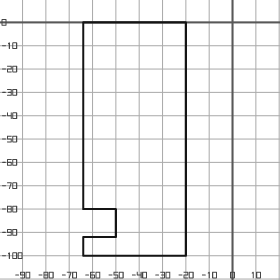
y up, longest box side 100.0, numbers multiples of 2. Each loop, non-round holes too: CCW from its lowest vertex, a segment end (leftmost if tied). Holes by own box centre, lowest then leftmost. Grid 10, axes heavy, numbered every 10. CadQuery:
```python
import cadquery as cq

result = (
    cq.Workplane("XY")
    .moveTo(-64.0, -100.0)
    .lineTo(-20.0, -100.0)
    .lineTo(-20.0, 0.0)
    .lineTo(-64.0, 0.0)
    .lineTo(-64.0, -80.0)
    .lineTo(-50.0, -80.0)
    .lineTo(-50.0, -92.0)
    .lineTo(-64.0, -92.0)
    .close()
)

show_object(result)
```